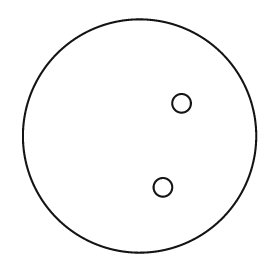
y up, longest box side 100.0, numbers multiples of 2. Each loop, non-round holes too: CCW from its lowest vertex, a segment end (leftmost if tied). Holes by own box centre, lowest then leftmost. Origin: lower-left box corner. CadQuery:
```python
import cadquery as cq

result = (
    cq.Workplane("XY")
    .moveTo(50.0, 50.0)
    .circle(50.0)
    .moveTo(60.0, 28.0)
    .circle(4.0)
    .moveTo(68.0, 64.0)
    .circle(4.0)
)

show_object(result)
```